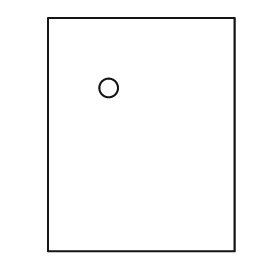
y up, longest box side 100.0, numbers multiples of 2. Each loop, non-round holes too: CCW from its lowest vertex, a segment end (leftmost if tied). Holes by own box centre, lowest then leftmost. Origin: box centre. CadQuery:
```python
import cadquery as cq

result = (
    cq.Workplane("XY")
    .moveTo(-40.0, -50.0)
    .lineTo(40.0, -50.0)
    .lineTo(40.0, 50.0)
    .lineTo(-40.0, 50.0)
    .close()
    .moveTo(-14.0, 20.0)
    .circle(4.0)
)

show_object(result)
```